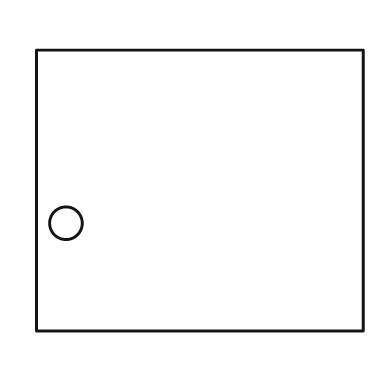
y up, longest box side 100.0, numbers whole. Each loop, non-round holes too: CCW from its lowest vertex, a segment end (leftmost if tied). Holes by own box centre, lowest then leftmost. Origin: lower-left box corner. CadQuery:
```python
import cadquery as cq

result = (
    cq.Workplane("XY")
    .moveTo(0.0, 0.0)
    .lineTo(100.0, 0.0)
    .lineTo(100.0, 86.0)
    .lineTo(0.0, 86.0)
    .close()
    .moveTo(9.0, 33.0)
    .circle(5.0)
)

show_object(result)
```